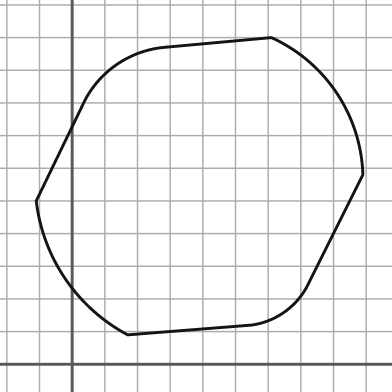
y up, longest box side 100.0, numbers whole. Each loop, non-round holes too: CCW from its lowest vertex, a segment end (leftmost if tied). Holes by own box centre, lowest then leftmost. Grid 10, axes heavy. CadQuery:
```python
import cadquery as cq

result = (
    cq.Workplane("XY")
    .moveTo(17.0, 9.0)
    .lineTo(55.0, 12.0)
    .threePointArc((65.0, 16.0), (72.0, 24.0))
    .lineTo(89.0, 58.0)
    .threePointArc((81.0, 83.0), (61.0, 100.0))
    .lineTo(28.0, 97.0)
    .threePointArc((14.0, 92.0), (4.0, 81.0))
    .lineTo(-11.0, 50.0)
    .threePointArc((-2.0, 26.0), (17.0, 9.0))
    .close()
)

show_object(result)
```